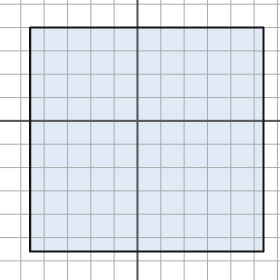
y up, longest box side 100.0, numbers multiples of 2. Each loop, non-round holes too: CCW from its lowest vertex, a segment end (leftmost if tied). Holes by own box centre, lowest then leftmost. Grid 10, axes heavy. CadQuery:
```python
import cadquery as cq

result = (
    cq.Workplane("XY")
    .moveTo(-46.0, -56.0)
    .lineTo(54.0, -56.0)
    .lineTo(54.0, 40.0)
    .lineTo(-46.0, 40.0)
    .close()
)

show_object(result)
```